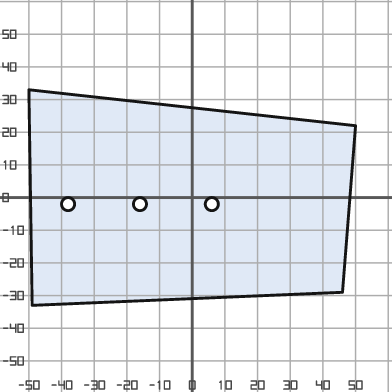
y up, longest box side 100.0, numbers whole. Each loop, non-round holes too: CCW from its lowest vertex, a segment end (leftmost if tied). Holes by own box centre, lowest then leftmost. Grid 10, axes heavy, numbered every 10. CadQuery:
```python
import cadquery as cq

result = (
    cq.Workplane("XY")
    .moveTo(-49.0, -33.0)
    .lineTo(46.0, -29.0)
    .lineTo(50.0, 22.0)
    .lineTo(-50.0, 33.0)
    .close()
    .moveTo(-38.0, -2.0)
    .circle(2.0)
    .moveTo(-16.0, -2.0)
    .circle(2.0)
    .moveTo(6.0, -2.0)
    .circle(2.0)
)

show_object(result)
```